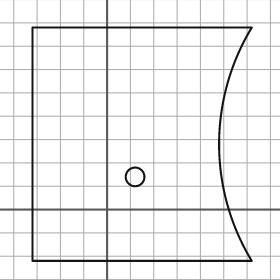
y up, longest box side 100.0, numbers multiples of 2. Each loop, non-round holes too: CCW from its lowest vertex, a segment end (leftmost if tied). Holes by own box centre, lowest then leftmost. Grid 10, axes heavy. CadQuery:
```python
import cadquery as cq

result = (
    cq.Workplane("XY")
    .moveTo(-32.0, -22.0)
    .lineTo(62.0, -22.0)
    .threePointArc((48.0, 28.0), (62.0, 78.0))
    .lineTo(-32.0, 78.0)
    .close()
    .moveTo(12.0, 14.0)
    .circle(4.0)
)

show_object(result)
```